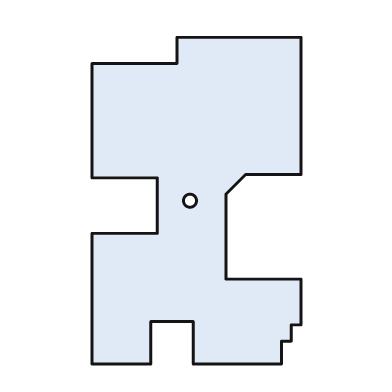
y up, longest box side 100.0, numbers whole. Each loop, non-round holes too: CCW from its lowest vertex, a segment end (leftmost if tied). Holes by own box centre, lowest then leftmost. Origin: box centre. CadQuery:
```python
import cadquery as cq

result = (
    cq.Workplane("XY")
    .moveTo(-32.0, -50.0)
    .lineTo(-14.0, -50.0)
    .lineTo(-14.0, -37.0)
    .lineTo(-1.0, -37.0)
    .lineTo(-1.0, -50.0)
    .lineTo(26.0, -50.0)
    .lineTo(26.0, -43.0)
    .lineTo(29.0, -43.0)
    .lineTo(29.0, -38.0)
    .lineTo(32.0, -38.0)
    .lineTo(32.0, -24.0)
    .lineTo(9.0, -24.0)
    .lineTo(9.0, 2.0)
    .lineTo(15.0, 8.0)
    .lineTo(32.0, 8.0)
    .lineTo(32.0, 50.0)
    .lineTo(-6.0, 50.0)
    .lineTo(-6.0, 42.0)
    .lineTo(-32.0, 42.0)
    .lineTo(-32.0, 7.0)
    .lineTo(-12.0, 7.0)
    .lineTo(-12.0, -10.0)
    .lineTo(-32.0, -10.0)
    .close()
    .moveTo(-2.0, 0.0)
    .circle(2.0)
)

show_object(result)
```